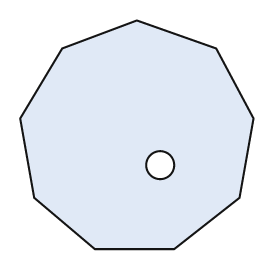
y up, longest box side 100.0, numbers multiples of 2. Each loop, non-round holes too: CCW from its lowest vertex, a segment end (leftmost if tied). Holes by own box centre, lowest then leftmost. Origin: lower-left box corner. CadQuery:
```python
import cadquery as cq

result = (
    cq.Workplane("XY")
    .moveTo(32.0, 0.0)
    .lineTo(66.0, 0.0)
    .lineTo(94.0, 22.0)
    .lineTo(100.0, 56.0)
    .lineTo(84.0, 86.0)
    .lineTo(50.0, 98.0)
    .lineTo(18.0, 86.0)
    .lineTo(0.0, 56.0)
    .lineTo(6.0, 22.0)
    .close()
    .moveTo(60.0, 36.0)
    .circle(6.0)
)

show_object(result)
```